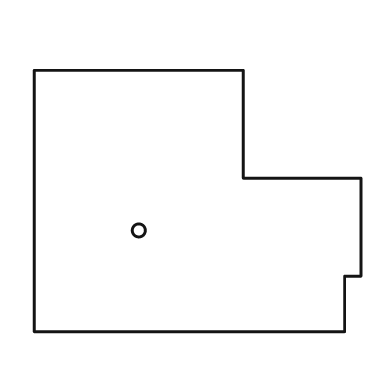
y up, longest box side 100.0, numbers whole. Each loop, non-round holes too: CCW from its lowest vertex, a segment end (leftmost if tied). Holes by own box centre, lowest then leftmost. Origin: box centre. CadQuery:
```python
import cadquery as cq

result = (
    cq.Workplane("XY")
    .moveTo(-50.0, -40.0)
    .lineTo(45.0, -40.0)
    .lineTo(45.0, -23.0)
    .lineTo(50.0, -23.0)
    .lineTo(50.0, 7.0)
    .lineTo(14.0, 7.0)
    .lineTo(14.0, 40.0)
    .lineTo(-50.0, 40.0)
    .close()
    .moveTo(-18.0, -9.0)
    .circle(2.0)
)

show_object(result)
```